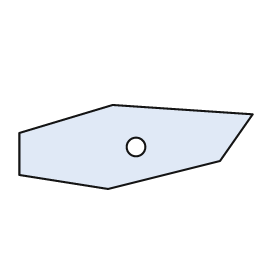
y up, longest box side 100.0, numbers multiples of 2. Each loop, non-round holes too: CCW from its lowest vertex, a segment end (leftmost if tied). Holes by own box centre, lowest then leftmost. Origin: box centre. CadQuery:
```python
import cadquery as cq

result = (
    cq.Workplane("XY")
    .moveTo(-12.0, -18.0)
    .lineTo(36.0, -6.0)
    .lineTo(50.0, 14.0)
    .lineTo(-10.0, 18.0)
    .lineTo(-50.0, 6.0)
    .lineTo(-50.0, -12.0)
    .close()
    .moveTo(0.0, 0.0)
    .circle(4.0)
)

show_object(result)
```